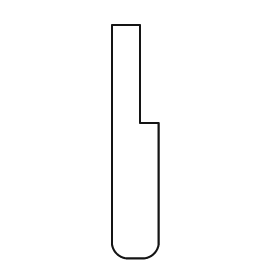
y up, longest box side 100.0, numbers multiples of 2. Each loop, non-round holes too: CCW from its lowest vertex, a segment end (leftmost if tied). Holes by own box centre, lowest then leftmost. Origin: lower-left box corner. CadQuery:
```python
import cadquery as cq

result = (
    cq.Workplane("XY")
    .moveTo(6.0, 0.0)
    .lineTo(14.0, 0.0)
    .threePointArc((18.0, 2.0), (20.0, 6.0))
    .lineTo(20.0, 58.0)
    .lineTo(12.0, 58.0)
    .lineTo(12.0, 100.0)
    .lineTo(0.0, 100.0)
    .lineTo(0.0, 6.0)
    .threePointArc((2.0, 2.0), (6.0, 0.0))
    .close()
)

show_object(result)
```